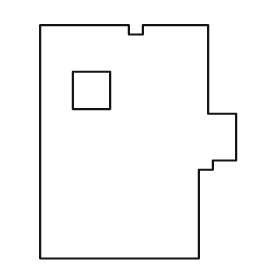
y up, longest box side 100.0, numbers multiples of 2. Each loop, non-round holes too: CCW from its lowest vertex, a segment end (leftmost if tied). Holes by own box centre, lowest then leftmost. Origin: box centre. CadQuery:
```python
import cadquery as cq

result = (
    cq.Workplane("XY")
    .moveTo(-42.0, -50.0)
    .lineTo(26.0, -50.0)
    .lineTo(26.0, -12.0)
    .lineTo(32.0, -12.0)
    .lineTo(32.0, -8.0)
    .lineTo(42.0, -8.0)
    .lineTo(42.0, 12.0)
    .lineTo(30.0, 12.0)
    .lineTo(30.0, 50.0)
    .lineTo(2.0, 50.0)
    .lineTo(2.0, 46.0)
    .lineTo(-4.0, 46.0)
    .lineTo(-4.0, 50.0)
    .lineTo(-42.0, 50.0)
    .close()
    .moveTo(-28.0, 14.0)
    .lineTo(-12.0, 14.0)
    .lineTo(-12.0, 30.0)
    .lineTo(-28.0, 30.0)
    .close()
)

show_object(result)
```